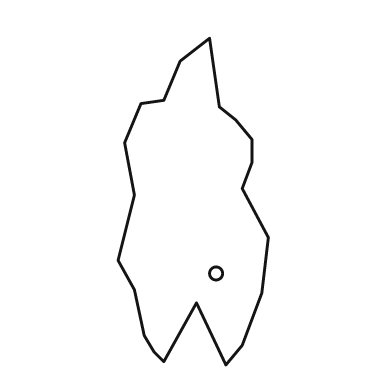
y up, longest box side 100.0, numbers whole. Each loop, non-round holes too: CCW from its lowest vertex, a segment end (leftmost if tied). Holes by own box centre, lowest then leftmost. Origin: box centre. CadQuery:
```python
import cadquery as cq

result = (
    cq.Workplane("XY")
    .moveTo(10.0, -50.0)
    .lineTo(15.0, -44.0)
    .lineTo(21.0, -28.0)
    .lineTo(23.0, -11.0)
    .lineTo(15.0, 4.0)
    .lineTo(18.0, 12.0)
    .lineTo(18.0, 19.0)
    .lineTo(13.0, 25.0)
    .lineTo(8.0, 29.0)
    .lineTo(5.0, 50.0)
    .lineTo(-4.0, 43.0)
    .lineTo(-9.0, 31.0)
    .lineTo(-16.0, 30.0)
    .lineTo(-21.0, 18.0)
    .lineTo(-18.0, 2.0)
    .lineTo(-23.0, -18.0)
    .lineTo(-18.0, -27.0)
    .lineTo(-15.0, -41.0)
    .lineTo(-12.0, -46.0)
    .lineTo(-9.0, -49.0)
    .lineTo(1.0, -31.0)
    .close()
    .moveTo(7.0, -22.0)
    .circle(2.0)
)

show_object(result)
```